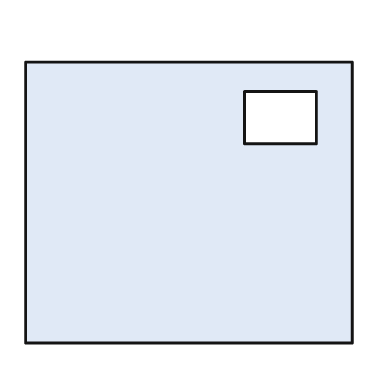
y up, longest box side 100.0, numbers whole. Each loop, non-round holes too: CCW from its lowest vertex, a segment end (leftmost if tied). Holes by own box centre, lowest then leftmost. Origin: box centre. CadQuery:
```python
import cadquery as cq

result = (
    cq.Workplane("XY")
    .moveTo(-50.0, -43.0)
    .lineTo(50.0, -43.0)
    .lineTo(50.0, 43.0)
    .lineTo(-50.0, 43.0)
    .close()
    .moveTo(17.0, 18.0)
    .lineTo(39.0, 18.0)
    .lineTo(39.0, 34.0)
    .lineTo(17.0, 34.0)
    .close()
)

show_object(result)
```